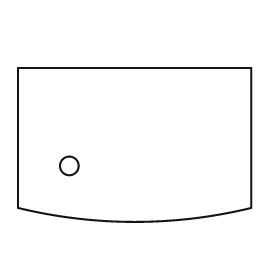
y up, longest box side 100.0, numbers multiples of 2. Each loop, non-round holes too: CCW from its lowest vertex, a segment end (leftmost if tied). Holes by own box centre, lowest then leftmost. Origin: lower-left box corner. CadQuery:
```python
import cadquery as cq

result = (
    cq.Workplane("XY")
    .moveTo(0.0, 6.0)
    .threePointArc((50.0, 0.0), (100.0, 6.0))
    .lineTo(100.0, 66.0)
    .lineTo(0.0, 66.0)
    .close()
    .moveTo(22.0, 24.0)
    .circle(4.0)
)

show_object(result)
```